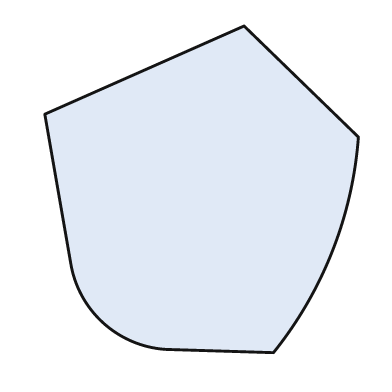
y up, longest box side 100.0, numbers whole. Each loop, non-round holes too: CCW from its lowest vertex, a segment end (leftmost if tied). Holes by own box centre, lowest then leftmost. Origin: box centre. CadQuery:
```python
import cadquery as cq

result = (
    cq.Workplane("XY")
    .moveTo(22.0, -50.0)
    .threePointArc((40.0, -19.0), (48.0, 16.0))
    .lineTo(13.0, 50.0)
    .lineTo(-48.0, 23.0)
    .lineTo(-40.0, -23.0)
    .threePointArc((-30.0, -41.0), (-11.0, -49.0))
    .close()
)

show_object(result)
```